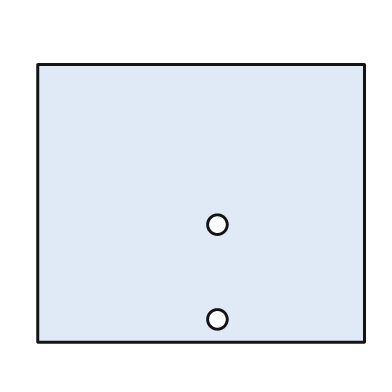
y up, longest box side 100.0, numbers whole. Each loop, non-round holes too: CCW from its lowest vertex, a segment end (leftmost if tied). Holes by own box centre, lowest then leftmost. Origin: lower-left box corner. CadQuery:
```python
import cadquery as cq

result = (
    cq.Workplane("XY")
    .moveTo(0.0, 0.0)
    .lineTo(100.0, 0.0)
    .lineTo(100.0, 85.0)
    .lineTo(0.0, 85.0)
    .close()
    .moveTo(55.0, 7.0)
    .circle(3.0)
    .moveTo(55.0, 36.0)
    .circle(3.0)
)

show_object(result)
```